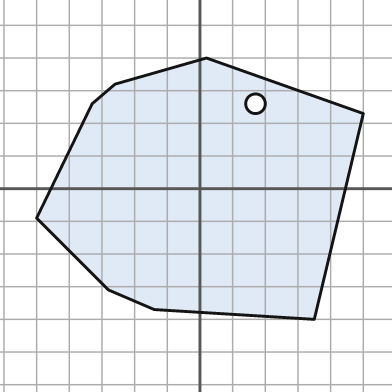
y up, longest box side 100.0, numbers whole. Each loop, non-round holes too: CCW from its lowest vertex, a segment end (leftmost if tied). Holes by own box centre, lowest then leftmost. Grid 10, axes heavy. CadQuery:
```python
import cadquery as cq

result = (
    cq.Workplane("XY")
    .moveTo(35.0, -40.0)
    .lineTo(50.0, 23.0)
    .lineTo(2.0, 40.0)
    .lineTo(-26.0, 32.0)
    .lineTo(-33.0, 26.0)
    .lineTo(-50.0, -9.0)
    .lineTo(-28.0, -31.0)
    .lineTo(-14.0, -37.0)
    .close()
    .moveTo(17.0, 26.0)
    .circle(3.0)
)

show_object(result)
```